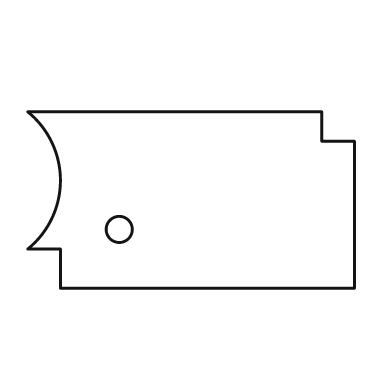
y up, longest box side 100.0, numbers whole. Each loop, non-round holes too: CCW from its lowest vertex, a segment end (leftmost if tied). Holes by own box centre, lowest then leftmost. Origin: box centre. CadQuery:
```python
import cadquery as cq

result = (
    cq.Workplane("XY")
    .moveTo(-40.0, -27.0)
    .lineTo(50.0, -27.0)
    .lineTo(50.0, 18.0)
    .lineTo(40.0, 18.0)
    .lineTo(40.0, 27.0)
    .lineTo(-50.0, 27.0)
    .threePointArc((-40.0, 6.0), (-50.0, -15.0))
    .lineTo(-40.0, -15.0)
    .close()
    .moveTo(-22.0, -9.0)
    .circle(4.0)
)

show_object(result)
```